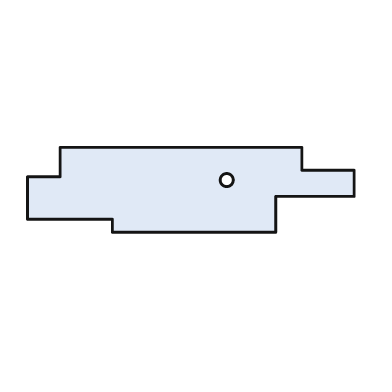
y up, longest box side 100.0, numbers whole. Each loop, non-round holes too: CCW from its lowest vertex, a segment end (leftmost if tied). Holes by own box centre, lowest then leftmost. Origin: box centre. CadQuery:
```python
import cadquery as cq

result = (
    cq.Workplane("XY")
    .moveTo(-24.0, -13.0)
    .lineTo(26.0, -13.0)
    .lineTo(26.0, -2.0)
    .lineTo(50.0, -2.0)
    .lineTo(50.0, 6.0)
    .lineTo(34.0, 6.0)
    .lineTo(34.0, 13.0)
    .lineTo(-40.0, 13.0)
    .lineTo(-40.0, 4.0)
    .lineTo(-50.0, 4.0)
    .lineTo(-50.0, -9.0)
    .lineTo(-24.0, -9.0)
    .close()
    .moveTo(11.0, 3.0)
    .circle(2.0)
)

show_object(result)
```